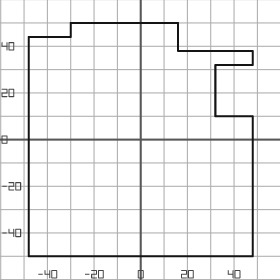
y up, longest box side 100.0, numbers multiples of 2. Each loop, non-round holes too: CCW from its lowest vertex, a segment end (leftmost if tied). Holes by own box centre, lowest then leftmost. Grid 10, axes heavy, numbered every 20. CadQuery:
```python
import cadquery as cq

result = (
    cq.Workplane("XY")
    .moveTo(-48.0, -50.0)
    .lineTo(48.0, -50.0)
    .lineTo(48.0, 10.0)
    .lineTo(32.0, 10.0)
    .lineTo(32.0, 32.0)
    .lineTo(48.0, 32.0)
    .lineTo(48.0, 38.0)
    .lineTo(16.0, 38.0)
    .lineTo(16.0, 50.0)
    .lineTo(-30.0, 50.0)
    .lineTo(-30.0, 44.0)
    .lineTo(-48.0, 44.0)
    .close()
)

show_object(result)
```